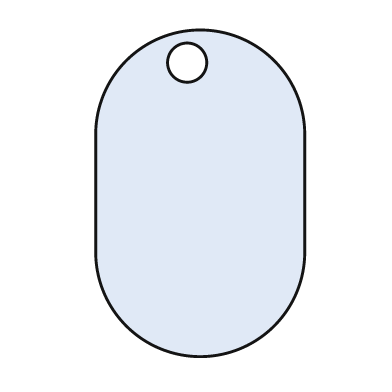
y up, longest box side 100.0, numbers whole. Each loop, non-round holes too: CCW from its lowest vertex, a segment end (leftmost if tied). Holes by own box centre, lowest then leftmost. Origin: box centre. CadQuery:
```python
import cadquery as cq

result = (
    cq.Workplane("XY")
    .moveTo(-32.0, -18.0)
    .threePointArc((0.0, -50.0), (32.0, -18.0))
    .lineTo(32.0, 18.0)
    .threePointArc((0.0, 50.0), (-32.0, 18.0))
    .close()
    .moveTo(-4.0, 40.0)
    .circle(6.0)
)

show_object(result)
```